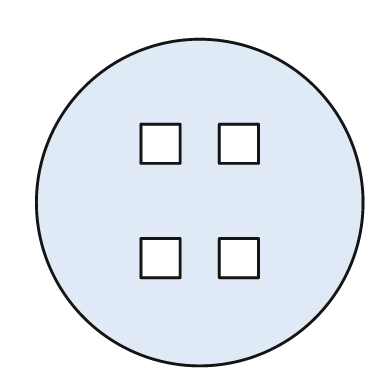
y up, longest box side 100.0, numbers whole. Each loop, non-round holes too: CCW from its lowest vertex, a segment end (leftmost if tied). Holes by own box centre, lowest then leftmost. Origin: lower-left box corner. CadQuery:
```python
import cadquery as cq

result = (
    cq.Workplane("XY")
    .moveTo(50.0, 50.0)
    .circle(50.0)
    .moveTo(32.0, 27.0)
    .lineTo(44.0, 27.0)
    .lineTo(44.0, 39.0)
    .lineTo(32.0, 39.0)
    .close()
    .moveTo(56.0, 27.0)
    .lineTo(68.0, 27.0)
    .lineTo(68.0, 39.0)
    .lineTo(56.0, 39.0)
    .close()
    .moveTo(32.0, 62.0)
    .lineTo(44.0, 62.0)
    .lineTo(44.0, 74.0)
    .lineTo(32.0, 74.0)
    .close()
    .moveTo(56.0, 62.0)
    .lineTo(68.0, 62.0)
    .lineTo(68.0, 74.0)
    .lineTo(56.0, 74.0)
    .close()
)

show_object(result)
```